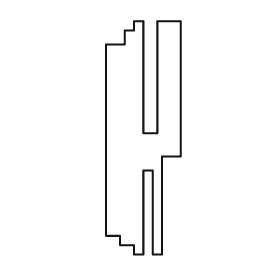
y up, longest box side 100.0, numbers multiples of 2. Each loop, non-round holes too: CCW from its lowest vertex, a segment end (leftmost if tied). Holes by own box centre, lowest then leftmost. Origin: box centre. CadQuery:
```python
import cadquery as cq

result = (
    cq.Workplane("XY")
    .moveTo(-4.0, -50.0)
    .lineTo(0.0, -50.0)
    .lineTo(0.0, -14.0)
    .lineTo(4.0, -14.0)
    .lineTo(4.0, -50.0)
    .lineTo(8.0, -50.0)
    .lineTo(8.0, -8.0)
    .lineTo(16.0, -8.0)
    .lineTo(16.0, 50.0)
    .lineTo(6.0, 50.0)
    .lineTo(6.0, 2.0)
    .lineTo(0.0, 2.0)
    .lineTo(0.0, 50.0)
    .lineTo(-4.0, 50.0)
    .lineTo(-4.0, 46.0)
    .lineTo(-8.0, 46.0)
    .lineTo(-8.0, 40.0)
    .lineTo(-16.0, 40.0)
    .lineTo(-16.0, -42.0)
    .lineTo(-10.0, -42.0)
    .lineTo(-10.0, -46.0)
    .lineTo(-4.0, -46.0)
    .close()
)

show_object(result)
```